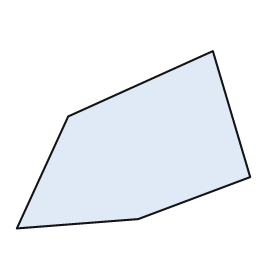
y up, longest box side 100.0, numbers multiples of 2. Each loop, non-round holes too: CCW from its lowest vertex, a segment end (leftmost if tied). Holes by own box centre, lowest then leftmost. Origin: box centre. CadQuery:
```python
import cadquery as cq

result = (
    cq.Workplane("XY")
    .moveTo(-50.0, -38.0)
    .lineTo(2.0, -34.0)
    .lineTo(50.0, -16.0)
    .lineTo(34.0, 38.0)
    .lineTo(-28.0, 10.0)
    .close()
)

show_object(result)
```